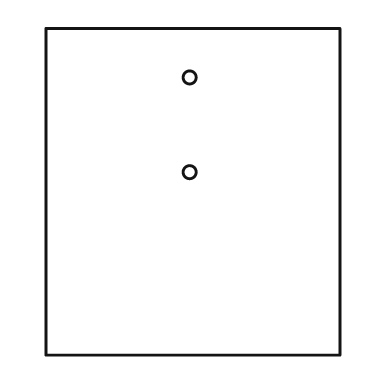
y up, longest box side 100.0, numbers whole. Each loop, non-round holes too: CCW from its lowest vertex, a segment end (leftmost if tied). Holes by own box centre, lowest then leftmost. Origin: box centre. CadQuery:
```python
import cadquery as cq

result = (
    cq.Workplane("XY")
    .moveTo(-45.0, -50.0)
    .lineTo(45.0, -50.0)
    .lineTo(45.0, 50.0)
    .lineTo(-45.0, 50.0)
    .close()
    .moveTo(-1.0, 6.0)
    .circle(2.0)
    .moveTo(-1.0, 35.0)
    .circle(2.0)
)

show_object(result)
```